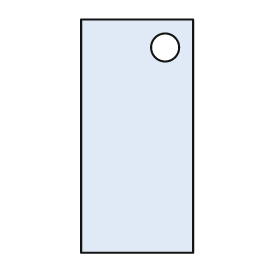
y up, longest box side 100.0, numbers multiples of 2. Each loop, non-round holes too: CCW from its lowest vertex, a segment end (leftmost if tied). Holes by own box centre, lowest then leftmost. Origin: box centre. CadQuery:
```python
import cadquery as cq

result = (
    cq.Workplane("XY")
    .moveTo(-24.0, -50.0)
    .lineTo(24.0, -50.0)
    .lineTo(24.0, 50.0)
    .lineTo(-24.0, 50.0)
    .close()
    .moveTo(12.0, 38.0)
    .circle(6.0)
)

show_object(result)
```